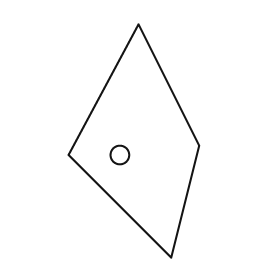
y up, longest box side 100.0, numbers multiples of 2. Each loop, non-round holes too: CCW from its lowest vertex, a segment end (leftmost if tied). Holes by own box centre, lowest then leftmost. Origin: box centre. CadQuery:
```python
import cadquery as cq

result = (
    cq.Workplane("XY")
    .moveTo(16.0, -50.0)
    .lineTo(28.0, -2.0)
    .lineTo(2.0, 50.0)
    .lineTo(-28.0, -6.0)
    .close()
    .moveTo(-6.0, -6.0)
    .circle(4.0)
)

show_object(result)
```